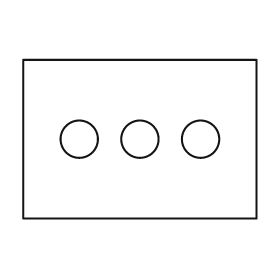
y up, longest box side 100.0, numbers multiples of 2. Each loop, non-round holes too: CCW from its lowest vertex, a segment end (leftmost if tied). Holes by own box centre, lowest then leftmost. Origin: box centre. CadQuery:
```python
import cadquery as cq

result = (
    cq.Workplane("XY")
    .moveTo(-50.0, -34.0)
    .lineTo(50.0, -34.0)
    .lineTo(50.0, 34.0)
    .lineTo(-50.0, 34.0)
    .close()
    .moveTo(-26.0, 0.0)
    .circle(8.0)
    .moveTo(0.0, 0.0)
    .circle(8.0)
    .moveTo(26.0, 0.0)
    .circle(8.0)
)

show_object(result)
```